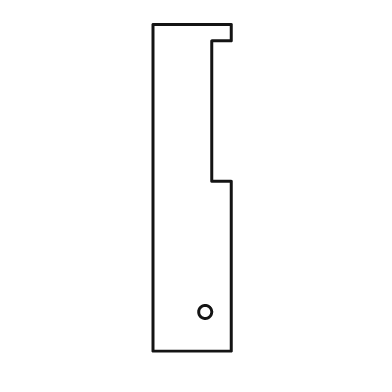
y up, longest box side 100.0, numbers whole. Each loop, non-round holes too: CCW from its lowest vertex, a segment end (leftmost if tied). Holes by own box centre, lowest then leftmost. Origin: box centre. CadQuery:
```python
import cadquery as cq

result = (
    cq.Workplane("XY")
    .moveTo(-12.0, -50.0)
    .lineTo(12.0, -50.0)
    .lineTo(12.0, 2.0)
    .lineTo(6.0, 2.0)
    .lineTo(6.0, 45.0)
    .lineTo(12.0, 45.0)
    .lineTo(12.0, 50.0)
    .lineTo(-12.0, 50.0)
    .close()
    .moveTo(4.0, -38.0)
    .circle(2.0)
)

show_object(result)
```